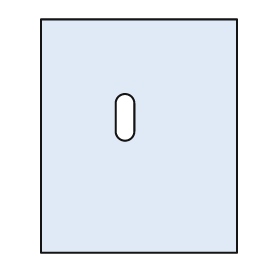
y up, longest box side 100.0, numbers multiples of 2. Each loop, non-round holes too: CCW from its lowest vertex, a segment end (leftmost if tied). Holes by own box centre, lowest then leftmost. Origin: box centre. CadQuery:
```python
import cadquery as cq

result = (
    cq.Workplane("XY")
    .moveTo(-42.0, -50.0)
    .lineTo(42.0, -50.0)
    .lineTo(42.0, 50.0)
    .lineTo(-42.0, 50.0)
    .close()
    .moveTo(-10.0, 2.0)
    .threePointArc((-6.0, -2.0), (-2.0, 2.0))
    .lineTo(-2.0, 14.0)
    .threePointArc((-6.0, 18.0), (-10.0, 14.0))
    .close()
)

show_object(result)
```